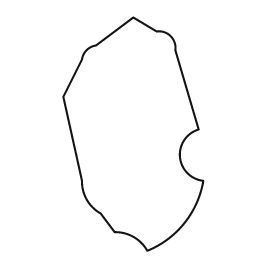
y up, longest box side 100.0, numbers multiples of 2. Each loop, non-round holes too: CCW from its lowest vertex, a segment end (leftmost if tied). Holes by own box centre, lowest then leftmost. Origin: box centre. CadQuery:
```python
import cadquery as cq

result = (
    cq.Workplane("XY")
    .moveTo(6.0, -50.0)
    .threePointArc((22.0, -38.0), (30.0, -20.0))
    .threePointArc((20.0, -10.0), (28.0, 2.0))
    .lineTo(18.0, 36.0)
    .threePointArc((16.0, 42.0), (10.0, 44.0))
    .lineTo(0.0, 50.0)
    .lineTo(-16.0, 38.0)
    .threePointArc((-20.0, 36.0), (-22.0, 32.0))
    .lineTo(-30.0, 16.0)
    .lineTo(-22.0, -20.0)
    .threePointArc((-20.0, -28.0), (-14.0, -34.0))
    .lineTo(-8.0, -42.0)
    .threePointArc((0.0, -44.0), (6.0, -50.0))
    .close()
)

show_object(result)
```